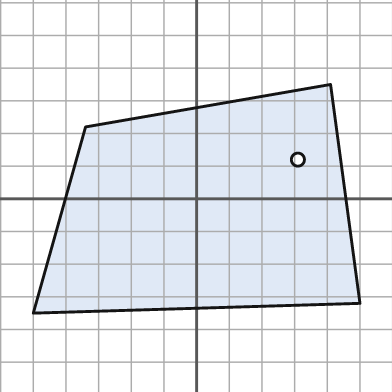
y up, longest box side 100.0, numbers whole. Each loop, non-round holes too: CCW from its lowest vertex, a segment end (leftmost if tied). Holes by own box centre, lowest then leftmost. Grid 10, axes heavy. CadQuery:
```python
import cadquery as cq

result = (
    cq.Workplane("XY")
    .moveTo(-50.0, -35.0)
    .lineTo(50.0, -32.0)
    .lineTo(41.0, 35.0)
    .lineTo(-34.0, 22.0)
    .close()
    .moveTo(31.0, 12.0)
    .circle(2.0)
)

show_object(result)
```